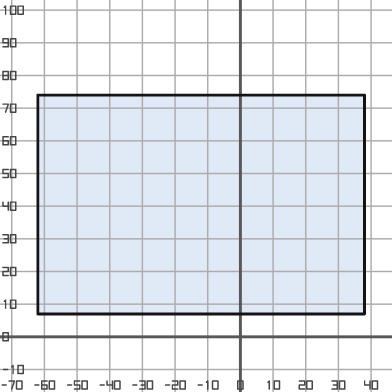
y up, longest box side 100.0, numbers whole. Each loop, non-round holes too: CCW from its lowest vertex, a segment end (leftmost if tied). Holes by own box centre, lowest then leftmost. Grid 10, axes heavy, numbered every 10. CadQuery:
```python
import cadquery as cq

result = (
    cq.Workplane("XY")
    .moveTo(-62.0, 7.0)
    .lineTo(38.0, 7.0)
    .lineTo(38.0, 74.0)
    .lineTo(-62.0, 74.0)
    .close()
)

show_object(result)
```